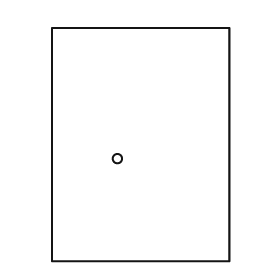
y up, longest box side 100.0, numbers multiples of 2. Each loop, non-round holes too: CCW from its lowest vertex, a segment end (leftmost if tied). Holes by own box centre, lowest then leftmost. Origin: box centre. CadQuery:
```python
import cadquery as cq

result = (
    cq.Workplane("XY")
    .moveTo(-38.0, -50.0)
    .lineTo(38.0, -50.0)
    .lineTo(38.0, 50.0)
    .lineTo(-38.0, 50.0)
    .close()
    .moveTo(-10.0, -6.0)
    .circle(2.0)
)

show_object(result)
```